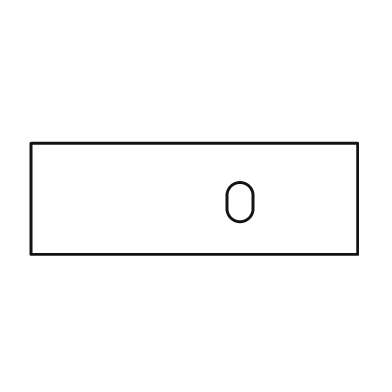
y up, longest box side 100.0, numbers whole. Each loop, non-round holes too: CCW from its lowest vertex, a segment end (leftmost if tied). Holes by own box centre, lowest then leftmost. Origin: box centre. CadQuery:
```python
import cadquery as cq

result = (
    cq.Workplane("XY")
    .moveTo(-50.0, -17.0)
    .lineTo(50.0, -17.0)
    .lineTo(50.0, 17.0)
    .lineTo(-50.0, 17.0)
    .close()
    .moveTo(10.0, -3.0)
    .threePointArc((14.0, -7.0), (18.0, -3.0))
    .lineTo(18.0, 1.0)
    .threePointArc((14.0, 5.0), (10.0, 1.0))
    .close()
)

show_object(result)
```